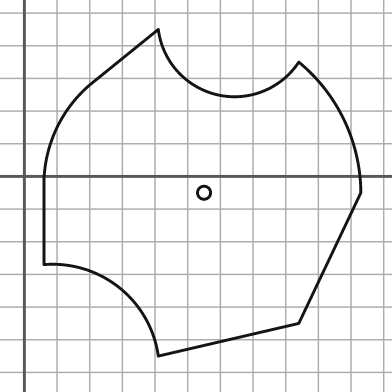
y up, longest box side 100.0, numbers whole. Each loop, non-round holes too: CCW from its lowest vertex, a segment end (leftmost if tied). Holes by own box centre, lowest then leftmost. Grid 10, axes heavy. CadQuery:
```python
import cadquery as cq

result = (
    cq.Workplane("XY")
    .moveTo(41.0, -55.0)
    .lineTo(84.0, -45.0)
    .lineTo(103.0, -5.0)
    .threePointArc((98.0, 17.0), (84.0, 35.0))
    .threePointArc((59.0, 25.0), (41.0, 45.0))
    .lineTo(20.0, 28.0)
    .threePointArc((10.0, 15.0), (6.0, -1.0))
    .lineTo(6.0, -27.0)
    .threePointArc((29.0, -34.0), (41.0, -55.0))
    .close()
    .moveTo(55.0, -5.0)
    .circle(2.0)
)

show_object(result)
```